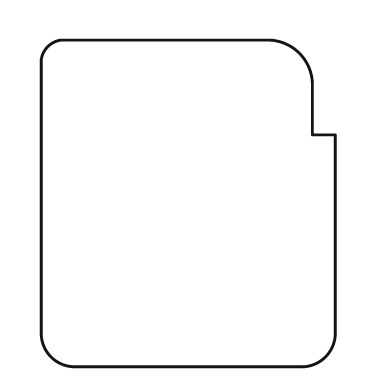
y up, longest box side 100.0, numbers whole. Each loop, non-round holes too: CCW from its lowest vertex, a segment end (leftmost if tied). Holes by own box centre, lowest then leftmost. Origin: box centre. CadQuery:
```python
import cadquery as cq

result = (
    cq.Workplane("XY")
    .moveTo(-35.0, -50.0)
    .lineTo(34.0, -50.0)
    .threePointArc((42.0, -47.0), (45.0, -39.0))
    .lineTo(45.0, 21.0)
    .lineTo(38.0, 21.0)
    .lineTo(38.0, 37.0)
    .threePointArc((34.0, 46.0), (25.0, 50.0))
    .lineTo(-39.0, 50.0)
    .threePointArc((-43.0, 48.0), (-45.0, 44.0))
    .lineTo(-45.0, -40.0)
    .threePointArc((-42.0, -47.0), (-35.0, -50.0))
    .close()
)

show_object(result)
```